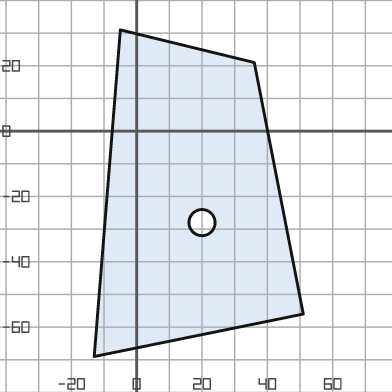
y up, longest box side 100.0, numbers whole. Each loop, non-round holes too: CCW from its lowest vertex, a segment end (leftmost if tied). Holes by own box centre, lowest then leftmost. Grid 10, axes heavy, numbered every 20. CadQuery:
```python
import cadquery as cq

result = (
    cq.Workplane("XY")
    .moveTo(-13.0, -69.0)
    .lineTo(51.0, -56.0)
    .lineTo(36.0, 21.0)
    .lineTo(-5.0, 31.0)
    .close()
    .moveTo(20.0, -28.0)
    .circle(4.0)
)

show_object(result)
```